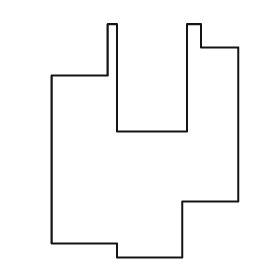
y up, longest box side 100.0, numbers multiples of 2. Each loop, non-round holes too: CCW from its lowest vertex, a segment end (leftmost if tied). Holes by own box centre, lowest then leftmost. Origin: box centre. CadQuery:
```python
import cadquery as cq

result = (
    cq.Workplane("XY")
    .moveTo(-12.0, -50.0)
    .lineTo(16.0, -50.0)
    .lineTo(16.0, -26.0)
    .lineTo(40.0, -26.0)
    .lineTo(40.0, 40.0)
    .lineTo(24.0, 40.0)
    .lineTo(24.0, 50.0)
    .lineTo(18.0, 50.0)
    .lineTo(18.0, 4.0)
    .lineTo(-12.0, 4.0)
    .lineTo(-12.0, 50.0)
    .lineTo(-16.0, 50.0)
    .lineTo(-16.0, 28.0)
    .lineTo(-40.0, 28.0)
    .lineTo(-40.0, -44.0)
    .lineTo(-12.0, -44.0)
    .close()
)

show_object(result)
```